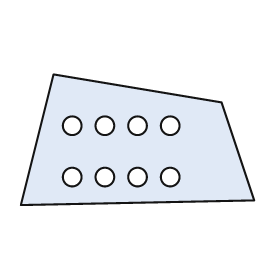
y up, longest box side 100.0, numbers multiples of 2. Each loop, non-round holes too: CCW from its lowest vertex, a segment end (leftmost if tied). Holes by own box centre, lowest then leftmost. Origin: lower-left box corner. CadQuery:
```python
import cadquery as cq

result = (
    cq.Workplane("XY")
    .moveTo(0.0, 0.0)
    .lineTo(100.0, 2.0)
    .lineTo(86.0, 44.0)
    .lineTo(14.0, 56.0)
    .close()
    .moveTo(22.0, 12.0)
    .circle(4.0)
    .moveTo(36.0, 12.0)
    .circle(4.0)
    .moveTo(50.0, 12.0)
    .circle(4.0)
    .moveTo(64.0, 12.0)
    .circle(4.0)
    .moveTo(22.0, 34.0)
    .circle(4.0)
    .moveTo(36.0, 34.0)
    .circle(4.0)
    .moveTo(50.0, 34.0)
    .circle(4.0)
    .moveTo(64.0, 34.0)
    .circle(4.0)
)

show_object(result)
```